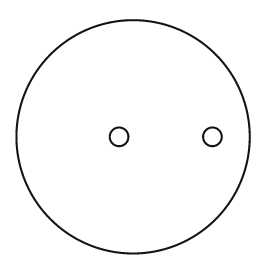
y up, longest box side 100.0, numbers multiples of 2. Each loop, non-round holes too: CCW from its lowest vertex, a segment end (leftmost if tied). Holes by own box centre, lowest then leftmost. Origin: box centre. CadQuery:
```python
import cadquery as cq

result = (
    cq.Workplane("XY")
    .moveTo(0.0, 0.0)
    .circle(50.0)
    .moveTo(-6.0, 0.0)
    .circle(4.0)
    .moveTo(34.0, 0.0)
    .circle(4.0)
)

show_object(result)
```